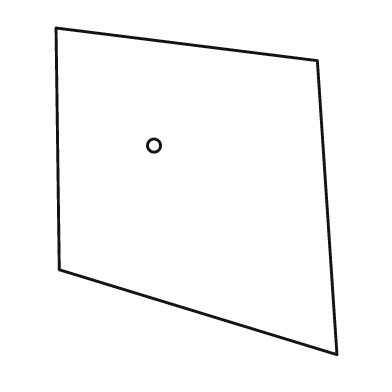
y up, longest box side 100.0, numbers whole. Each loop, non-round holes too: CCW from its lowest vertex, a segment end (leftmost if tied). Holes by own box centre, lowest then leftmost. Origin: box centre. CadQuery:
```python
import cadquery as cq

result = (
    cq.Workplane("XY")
    .moveTo(43.0, -50.0)
    .lineTo(37.0, 40.0)
    .lineTo(-43.0, 50.0)
    .lineTo(-42.0, -24.0)
    .close()
    .moveTo(-13.0, 14.0)
    .circle(2.0)
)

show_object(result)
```